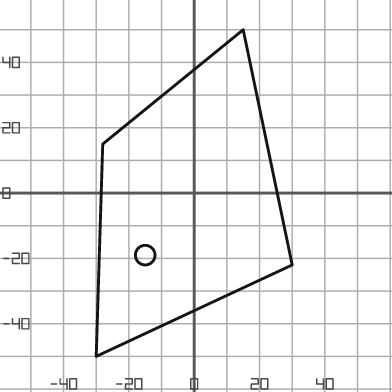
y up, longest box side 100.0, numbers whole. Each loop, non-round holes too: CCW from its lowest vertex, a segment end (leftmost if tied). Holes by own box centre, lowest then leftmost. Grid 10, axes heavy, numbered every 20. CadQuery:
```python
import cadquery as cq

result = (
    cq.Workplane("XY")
    .moveTo(-30.0, -50.0)
    .lineTo(30.0, -22.0)
    .lineTo(15.0, 50.0)
    .lineTo(-28.0, 15.0)
    .close()
    .moveTo(-15.0, -19.0)
    .circle(3.0)
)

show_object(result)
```